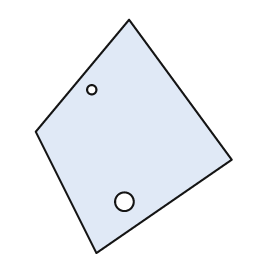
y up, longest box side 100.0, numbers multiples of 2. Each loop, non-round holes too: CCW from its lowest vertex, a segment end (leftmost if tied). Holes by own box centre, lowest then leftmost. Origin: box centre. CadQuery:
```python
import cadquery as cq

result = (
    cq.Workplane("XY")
    .moveTo(-16.0, -50.0)
    .lineTo(42.0, -10.0)
    .lineTo(-2.0, 50.0)
    .lineTo(-42.0, 2.0)
    .close()
    .moveTo(-4.0, -28.0)
    .circle(4.0)
    .moveTo(-18.0, 20.0)
    .circle(2.0)
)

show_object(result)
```